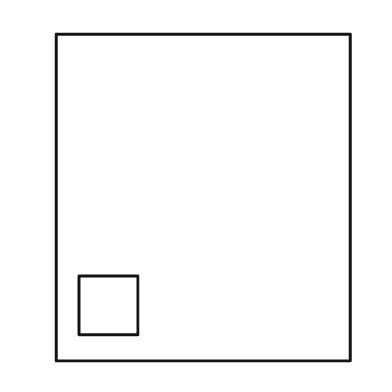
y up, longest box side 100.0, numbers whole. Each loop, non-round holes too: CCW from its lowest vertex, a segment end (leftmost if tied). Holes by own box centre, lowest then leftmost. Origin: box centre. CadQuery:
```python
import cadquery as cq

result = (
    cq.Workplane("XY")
    .moveTo(-45.0, -50.0)
    .lineTo(45.0, -50.0)
    .lineTo(45.0, 50.0)
    .lineTo(-45.0, 50.0)
    .close()
    .moveTo(-38.0, -42.0)
    .lineTo(-20.0, -42.0)
    .lineTo(-20.0, -24.0)
    .lineTo(-38.0, -24.0)
    .close()
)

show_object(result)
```